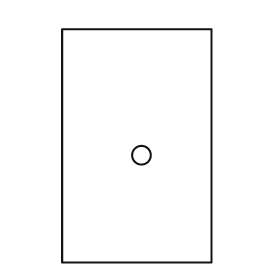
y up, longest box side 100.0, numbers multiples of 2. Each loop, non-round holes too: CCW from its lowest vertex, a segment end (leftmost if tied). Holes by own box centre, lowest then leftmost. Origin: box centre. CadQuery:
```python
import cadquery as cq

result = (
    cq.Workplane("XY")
    .moveTo(-32.0, -50.0)
    .lineTo(32.0, -50.0)
    .lineTo(32.0, 50.0)
    .lineTo(-32.0, 50.0)
    .close()
    .moveTo(2.0, -4.0)
    .circle(4.0)
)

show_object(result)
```